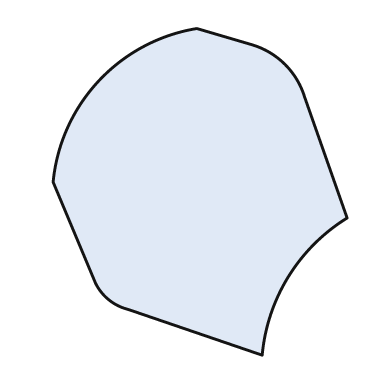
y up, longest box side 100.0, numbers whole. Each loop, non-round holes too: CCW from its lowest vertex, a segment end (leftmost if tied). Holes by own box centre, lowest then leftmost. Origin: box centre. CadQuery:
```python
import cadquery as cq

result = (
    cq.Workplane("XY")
    .moveTo(19.0, -50.0)
    .threePointArc((27.0, -26.0), (45.0, -8.0))
    .lineTo(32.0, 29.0)
    .threePointArc((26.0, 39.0), (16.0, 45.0))
    .lineTo(-1.0, 50.0)
    .threePointArc((-31.0, 34.0), (-45.0, 3.0))
    .lineTo(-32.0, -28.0)
    .threePointArc((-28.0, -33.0), (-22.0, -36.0))
    .close()
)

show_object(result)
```